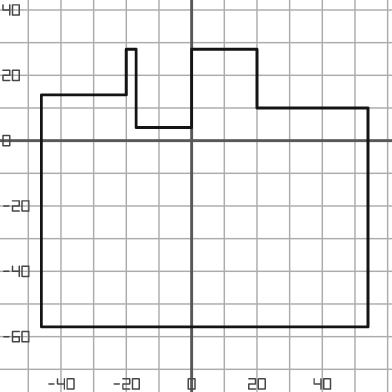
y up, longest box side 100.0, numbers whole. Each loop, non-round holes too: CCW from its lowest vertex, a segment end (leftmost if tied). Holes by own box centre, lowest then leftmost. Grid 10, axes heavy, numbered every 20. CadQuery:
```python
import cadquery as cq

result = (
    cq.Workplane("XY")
    .moveTo(-46.0, -57.0)
    .lineTo(54.0, -57.0)
    .lineTo(54.0, 10.0)
    .lineTo(20.0, 10.0)
    .lineTo(20.0, 28.0)
    .lineTo(0.0, 28.0)
    .lineTo(0.0, 4.0)
    .lineTo(-17.0, 4.0)
    .lineTo(-17.0, 28.0)
    .lineTo(-20.0, 28.0)
    .lineTo(-20.0, 14.0)
    .lineTo(-46.0, 14.0)
    .close()
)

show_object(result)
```